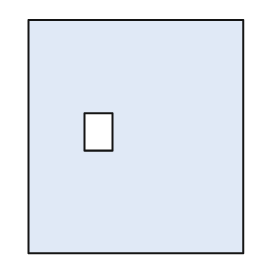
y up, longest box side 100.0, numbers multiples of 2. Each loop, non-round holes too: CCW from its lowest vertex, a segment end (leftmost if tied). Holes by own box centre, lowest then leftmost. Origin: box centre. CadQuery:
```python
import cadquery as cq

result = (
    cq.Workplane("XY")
    .moveTo(-46.0, -50.0)
    .lineTo(46.0, -50.0)
    .lineTo(46.0, 50.0)
    .lineTo(-46.0, 50.0)
    .close()
    .moveTo(-22.0, -6.0)
    .lineTo(-10.0, -6.0)
    .lineTo(-10.0, 10.0)
    .lineTo(-22.0, 10.0)
    .close()
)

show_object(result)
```